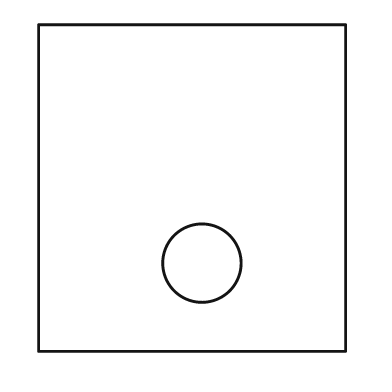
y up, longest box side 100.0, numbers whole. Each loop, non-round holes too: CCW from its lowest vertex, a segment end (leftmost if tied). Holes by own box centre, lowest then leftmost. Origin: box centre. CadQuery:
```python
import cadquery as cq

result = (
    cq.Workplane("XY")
    .moveTo(-47.0, -50.0)
    .lineTo(47.0, -50.0)
    .lineTo(47.0, 50.0)
    .lineTo(-47.0, 50.0)
    .close()
    .moveTo(3.0, -23.0)
    .circle(12.0)
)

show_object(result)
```